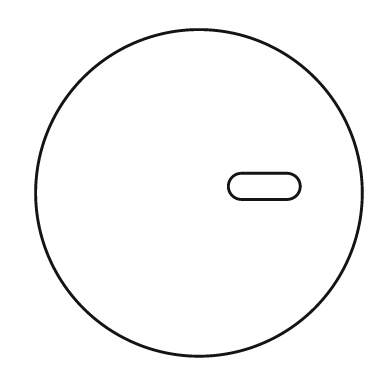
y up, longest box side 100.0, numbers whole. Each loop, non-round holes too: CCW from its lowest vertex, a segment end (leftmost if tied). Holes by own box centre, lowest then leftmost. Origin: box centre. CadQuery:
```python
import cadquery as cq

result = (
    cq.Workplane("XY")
    .moveTo(0.0, 0.0)
    .circle(50.0)
    .moveTo(13.0, -2.0)
    .lineTo(27.0, -2.0)
    .threePointArc((31.0, 2.0), (27.0, 6.0))
    .lineTo(13.0, 6.0)
    .threePointArc((9.0, 2.0), (13.0, -2.0))
    .close()
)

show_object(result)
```